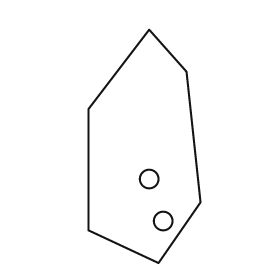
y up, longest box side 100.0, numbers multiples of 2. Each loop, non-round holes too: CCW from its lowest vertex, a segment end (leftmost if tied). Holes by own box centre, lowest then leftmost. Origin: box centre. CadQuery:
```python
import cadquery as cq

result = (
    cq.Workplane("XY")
    .moveTo(6.0, -50.0)
    .lineTo(24.0, -24.0)
    .lineTo(18.0, 32.0)
    .lineTo(2.0, 50.0)
    .lineTo(-24.0, 16.0)
    .lineTo(-24.0, -36.0)
    .close()
    .moveTo(8.0, -32.0)
    .circle(4.0)
    .moveTo(2.0, -14.0)
    .circle(4.0)
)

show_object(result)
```